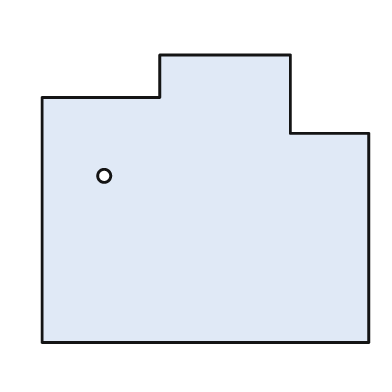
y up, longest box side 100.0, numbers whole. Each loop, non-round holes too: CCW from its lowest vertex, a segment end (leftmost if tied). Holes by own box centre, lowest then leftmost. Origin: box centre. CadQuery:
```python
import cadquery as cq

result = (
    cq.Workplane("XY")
    .moveTo(-50.0, -44.0)
    .lineTo(50.0, -44.0)
    .lineTo(50.0, 20.0)
    .lineTo(26.0, 20.0)
    .lineTo(26.0, 44.0)
    .lineTo(-14.0, 44.0)
    .lineTo(-14.0, 31.0)
    .lineTo(-50.0, 31.0)
    .close()
    .moveTo(-31.0, 7.0)
    .circle(2.0)
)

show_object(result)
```